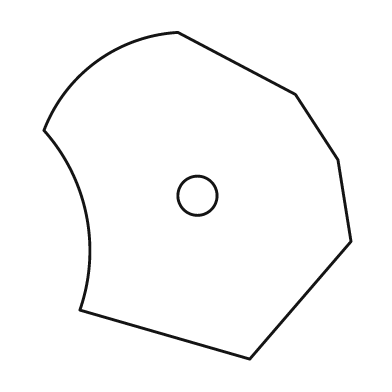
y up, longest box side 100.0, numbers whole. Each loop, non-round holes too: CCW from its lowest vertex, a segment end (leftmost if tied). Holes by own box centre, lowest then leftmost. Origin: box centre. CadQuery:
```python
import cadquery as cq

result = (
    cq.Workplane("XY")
    .moveTo(16.0, -50.0)
    .lineTo(47.0, -14.0)
    .lineTo(43.0, 11.0)
    .lineTo(30.0, 31.0)
    .lineTo(-6.0, 50.0)
    .threePointArc((-31.0, 41.0), (-47.0, 20.0))
    .threePointArc((-34.0, -6.0), (-36.0, -35.0))
    .close()
    .moveTo(0.0, 0.0)
    .circle(6.0)
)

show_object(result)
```